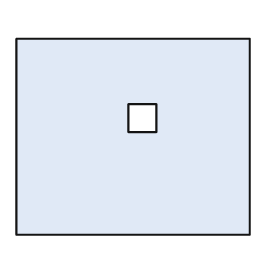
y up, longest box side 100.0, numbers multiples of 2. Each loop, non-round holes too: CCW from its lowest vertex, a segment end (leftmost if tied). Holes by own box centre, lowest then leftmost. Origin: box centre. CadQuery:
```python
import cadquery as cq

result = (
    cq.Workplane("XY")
    .moveTo(-50.0, -42.0)
    .lineTo(50.0, -42.0)
    .lineTo(50.0, 42.0)
    .lineTo(-50.0, 42.0)
    .close()
    .moveTo(-2.0, 2.0)
    .lineTo(10.0, 2.0)
    .lineTo(10.0, 14.0)
    .lineTo(-2.0, 14.0)
    .close()
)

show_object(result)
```